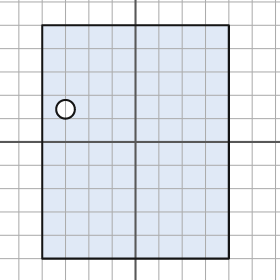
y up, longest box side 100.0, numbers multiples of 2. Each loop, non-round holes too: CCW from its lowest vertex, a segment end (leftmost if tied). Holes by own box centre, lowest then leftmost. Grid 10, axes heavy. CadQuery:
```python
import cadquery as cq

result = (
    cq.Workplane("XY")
    .moveTo(-40.0, -50.0)
    .lineTo(40.0, -50.0)
    .lineTo(40.0, 50.0)
    .lineTo(-40.0, 50.0)
    .close()
    .moveTo(-30.0, 14.0)
    .circle(4.0)
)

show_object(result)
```